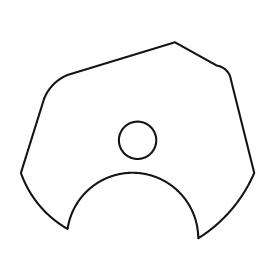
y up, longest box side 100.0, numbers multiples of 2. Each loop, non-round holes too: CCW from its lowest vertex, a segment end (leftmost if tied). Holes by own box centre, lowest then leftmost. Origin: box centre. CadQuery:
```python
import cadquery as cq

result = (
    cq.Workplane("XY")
    .moveTo(26.0, -42.0)
    .threePointArc((40.0, -30.0), (50.0, -14.0))
    .lineTo(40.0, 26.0)
    .threePointArc((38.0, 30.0), (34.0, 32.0))
    .lineTo(16.0, 42.0)
    .lineTo(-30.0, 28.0)
    .threePointArc((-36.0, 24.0), (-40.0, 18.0))
    .lineTo(-50.0, -14.0)
    .threePointArc((-42.0, -28.0), (-30.0, -38.0))
    .threePointArc((0.0, -14.0), (26.0, -42.0))
    .close()
    .moveTo(0.0, 0.0)
    .circle(8.0)
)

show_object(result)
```